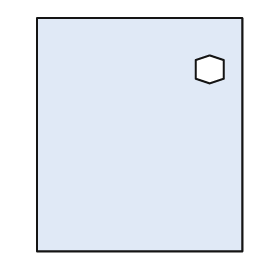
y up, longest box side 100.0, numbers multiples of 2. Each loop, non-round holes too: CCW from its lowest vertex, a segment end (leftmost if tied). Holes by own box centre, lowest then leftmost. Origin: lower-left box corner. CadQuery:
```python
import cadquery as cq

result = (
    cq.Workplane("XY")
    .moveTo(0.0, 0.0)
    .lineTo(88.0, 0.0)
    .lineTo(88.0, 100.0)
    .lineTo(0.0, 100.0)
    .close()
    .moveTo(74.0, 72.0)
    .lineTo(80.0, 74.0)
    .lineTo(80.0, 82.0)
    .lineTo(74.0, 84.0)
    .lineTo(68.0, 82.0)
    .lineTo(68.0, 74.0)
    .close()
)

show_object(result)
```